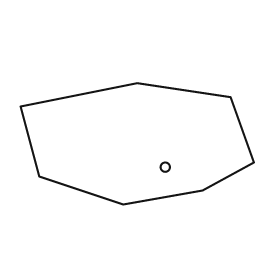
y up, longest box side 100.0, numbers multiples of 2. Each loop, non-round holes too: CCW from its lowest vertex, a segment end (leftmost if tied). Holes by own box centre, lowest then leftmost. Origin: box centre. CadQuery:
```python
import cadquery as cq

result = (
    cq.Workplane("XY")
    .moveTo(-6.0, -26.0)
    .lineTo(28.0, -20.0)
    .lineTo(50.0, -8.0)
    .lineTo(40.0, 20.0)
    .lineTo(0.0, 26.0)
    .lineTo(-50.0, 16.0)
    .lineTo(-42.0, -14.0)
    .close()
    .moveTo(12.0, -10.0)
    .circle(2.0)
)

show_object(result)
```